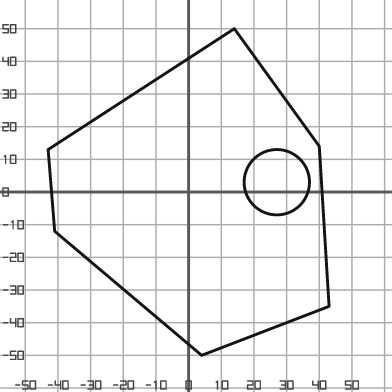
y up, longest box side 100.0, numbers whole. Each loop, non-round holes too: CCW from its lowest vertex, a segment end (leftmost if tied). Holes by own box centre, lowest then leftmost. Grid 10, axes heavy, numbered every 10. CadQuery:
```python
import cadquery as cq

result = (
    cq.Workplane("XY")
    .moveTo(4.0, -50.0)
    .lineTo(43.0, -35.0)
    .lineTo(40.0, 14.0)
    .lineTo(14.0, 50.0)
    .lineTo(-43.0, 13.0)
    .lineTo(-41.0, -12.0)
    .close()
    .moveTo(27.0, 3.0)
    .circle(10.0)
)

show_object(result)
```